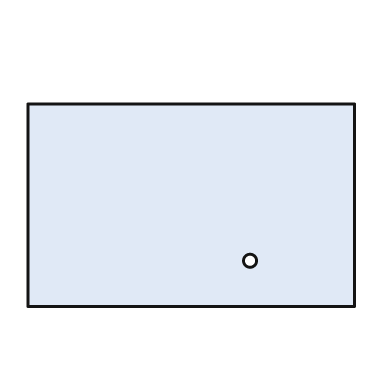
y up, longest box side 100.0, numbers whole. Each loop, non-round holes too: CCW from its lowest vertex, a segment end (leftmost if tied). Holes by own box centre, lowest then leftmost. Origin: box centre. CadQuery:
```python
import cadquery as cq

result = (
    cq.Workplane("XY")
    .moveTo(-50.0, -31.0)
    .lineTo(50.0, -31.0)
    .lineTo(50.0, 31.0)
    .lineTo(-50.0, 31.0)
    .close()
    .moveTo(18.0, -17.0)
    .circle(2.0)
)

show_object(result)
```